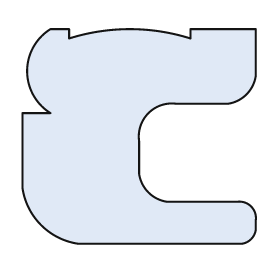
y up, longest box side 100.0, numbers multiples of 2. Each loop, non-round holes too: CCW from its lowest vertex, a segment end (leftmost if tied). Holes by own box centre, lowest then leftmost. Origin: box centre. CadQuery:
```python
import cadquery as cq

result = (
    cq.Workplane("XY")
    .moveTo(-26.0, -46.0)
    .lineTo(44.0, -46.0)
    .threePointArc((48.0, -44.0), (50.0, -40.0))
    .lineTo(50.0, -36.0)
    .threePointArc((48.0, -30.0), (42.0, -28.0))
    .lineTo(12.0, -28.0)
    .threePointArc((4.0, -24.0), (0.0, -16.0))
    .lineTo(0.0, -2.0)
    .threePointArc((4.0, 10.0), (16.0, 14.0))
    .lineTo(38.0, 14.0)
    .threePointArc((46.0, 18.0), (50.0, 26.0))
    .lineTo(50.0, 46.0)
    .lineTo(22.0, 46.0)
    .lineTo(22.0, 42.0)
    .threePointArc((-4.0, 46.0), (-30.0, 42.0))
    .lineTo(-30.0, 46.0)
    .lineTo(-38.0, 46.0)
    .threePointArc((-48.0, 28.0), (-38.0, 10.0))
    .lineTo(-50.0, 10.0)
    .lineTo(-50.0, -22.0)
    .threePointArc((-42.0, -38.0), (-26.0, -46.0))
    .close()
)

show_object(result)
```